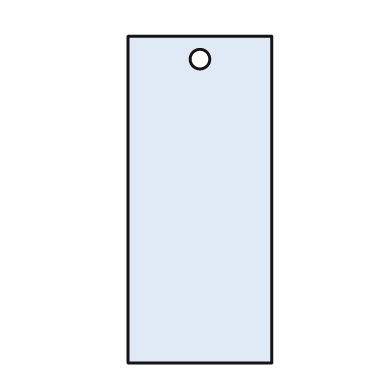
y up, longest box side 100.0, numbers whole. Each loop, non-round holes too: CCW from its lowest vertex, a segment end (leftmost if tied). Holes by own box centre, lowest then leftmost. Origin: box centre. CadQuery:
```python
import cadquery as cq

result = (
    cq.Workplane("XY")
    .moveTo(-22.0, -50.0)
    .lineTo(22.0, -50.0)
    .lineTo(22.0, 50.0)
    .lineTo(-22.0, 50.0)
    .close()
    .moveTo(0.0, 43.0)
    .circle(3.0)
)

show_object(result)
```